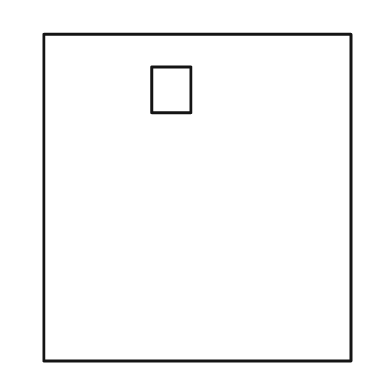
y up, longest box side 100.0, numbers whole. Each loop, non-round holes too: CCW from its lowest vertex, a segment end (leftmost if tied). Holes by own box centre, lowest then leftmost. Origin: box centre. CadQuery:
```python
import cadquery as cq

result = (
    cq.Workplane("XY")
    .moveTo(-47.0, -50.0)
    .lineTo(47.0, -50.0)
    .lineTo(47.0, 50.0)
    .lineTo(-47.0, 50.0)
    .close()
    .moveTo(-14.0, 26.0)
    .lineTo(-2.0, 26.0)
    .lineTo(-2.0, 40.0)
    .lineTo(-14.0, 40.0)
    .close()
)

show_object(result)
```